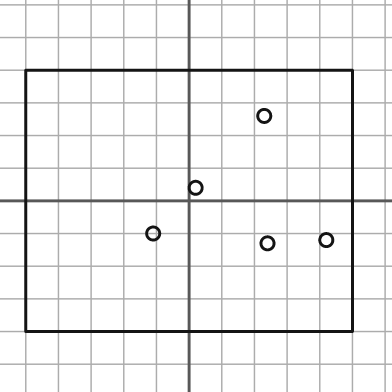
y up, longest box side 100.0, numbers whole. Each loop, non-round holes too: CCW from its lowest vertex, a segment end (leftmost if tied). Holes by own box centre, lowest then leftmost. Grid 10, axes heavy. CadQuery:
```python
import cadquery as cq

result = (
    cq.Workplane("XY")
    .moveTo(-50.0, -40.0)
    .lineTo(50.0, -40.0)
    .lineTo(50.0, 40.0)
    .lineTo(-50.0, 40.0)
    .close()
    .moveTo(24.0, -13.0)
    .circle(2.0)
    .moveTo(42.0, -12.0)
    .circle(2.0)
    .moveTo(-11.0, -10.0)
    .circle(2.0)
    .moveTo(2.0, 4.0)
    .circle(2.0)
    .moveTo(23.0, 26.0)
    .circle(2.0)
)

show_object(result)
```